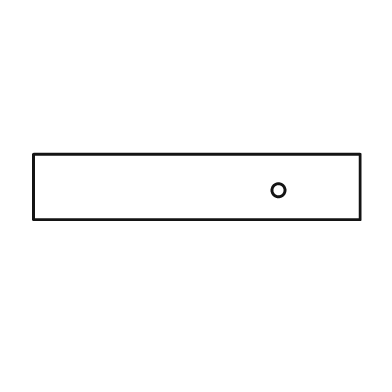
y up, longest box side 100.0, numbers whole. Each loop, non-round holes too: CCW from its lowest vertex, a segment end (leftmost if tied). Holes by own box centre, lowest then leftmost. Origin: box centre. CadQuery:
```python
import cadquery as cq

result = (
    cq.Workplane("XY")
    .moveTo(-50.0, -10.0)
    .lineTo(50.0, -10.0)
    .lineTo(50.0, 10.0)
    .lineTo(-50.0, 10.0)
    .close()
    .moveTo(25.0, -1.0)
    .circle(2.0)
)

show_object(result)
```